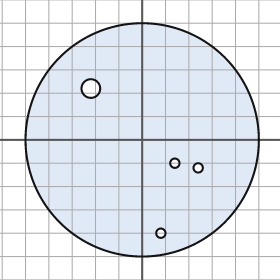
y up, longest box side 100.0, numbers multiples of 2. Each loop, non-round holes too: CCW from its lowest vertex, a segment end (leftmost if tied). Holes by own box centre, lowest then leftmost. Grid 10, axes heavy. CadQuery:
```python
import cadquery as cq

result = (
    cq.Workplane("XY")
    .moveTo(0.0, 0.0)
    .circle(50.0)
    .moveTo(8.0, -40.0)
    .circle(2.0)
    .moveTo(24.0, -12.0)
    .circle(2.0)
    .moveTo(14.0, -10.0)
    .circle(2.0)
    .moveTo(-22.0, 22.0)
    .circle(4.0)
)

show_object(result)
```